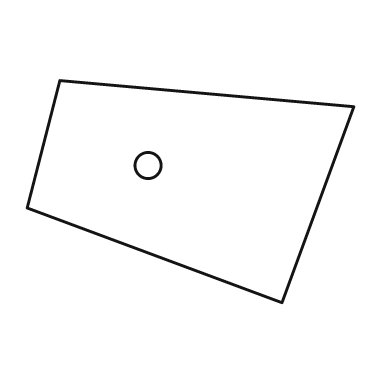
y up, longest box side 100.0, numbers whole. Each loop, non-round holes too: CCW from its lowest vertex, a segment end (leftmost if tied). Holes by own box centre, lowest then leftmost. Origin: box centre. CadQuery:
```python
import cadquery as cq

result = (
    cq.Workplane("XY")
    .moveTo(28.0, -34.0)
    .lineTo(50.0, 26.0)
    .lineTo(-40.0, 34.0)
    .lineTo(-50.0, -5.0)
    .close()
    .moveTo(-13.0, 8.0)
    .circle(4.0)
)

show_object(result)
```